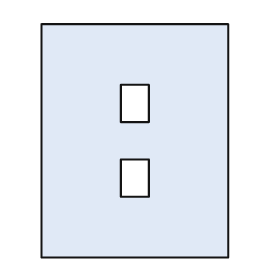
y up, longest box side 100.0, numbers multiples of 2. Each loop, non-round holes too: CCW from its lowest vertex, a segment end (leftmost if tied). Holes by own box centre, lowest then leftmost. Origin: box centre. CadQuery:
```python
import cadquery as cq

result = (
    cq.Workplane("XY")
    .moveTo(-40.0, -50.0)
    .lineTo(40.0, -50.0)
    .lineTo(40.0, 50.0)
    .lineTo(-40.0, 50.0)
    .close()
    .moveTo(-6.0, -24.0)
    .lineTo(6.0, -24.0)
    .lineTo(6.0, -8.0)
    .lineTo(-6.0, -8.0)
    .close()
    .moveTo(-6.0, 8.0)
    .lineTo(6.0, 8.0)
    .lineTo(6.0, 24.0)
    .lineTo(-6.0, 24.0)
    .close()
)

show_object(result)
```